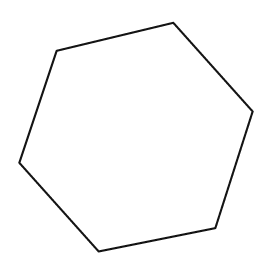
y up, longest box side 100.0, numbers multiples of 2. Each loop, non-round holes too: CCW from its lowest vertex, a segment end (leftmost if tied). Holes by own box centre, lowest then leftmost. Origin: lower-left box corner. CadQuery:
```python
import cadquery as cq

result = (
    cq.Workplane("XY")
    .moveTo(34.0, 0.0)
    .lineTo(84.0, 10.0)
    .lineTo(100.0, 60.0)
    .lineTo(66.0, 98.0)
    .lineTo(16.0, 86.0)
    .lineTo(0.0, 38.0)
    .close()
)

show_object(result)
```